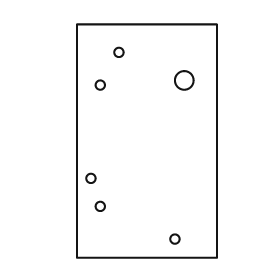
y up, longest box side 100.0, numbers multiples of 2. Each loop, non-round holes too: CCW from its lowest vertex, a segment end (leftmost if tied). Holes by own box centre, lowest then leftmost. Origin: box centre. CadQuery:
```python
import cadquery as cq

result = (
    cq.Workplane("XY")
    .moveTo(-30.0, -50.0)
    .lineTo(30.0, -50.0)
    .lineTo(30.0, 50.0)
    .lineTo(-30.0, 50.0)
    .close()
    .moveTo(12.0, -42.0)
    .circle(2.0)
    .moveTo(-20.0, -28.0)
    .circle(2.0)
    .moveTo(-24.0, -16.0)
    .circle(2.0)
    .moveTo(-20.0, 24.0)
    .circle(2.0)
    .moveTo(16.0, 26.0)
    .circle(4.0)
    .moveTo(-12.0, 38.0)
    .circle(2.0)
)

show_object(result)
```